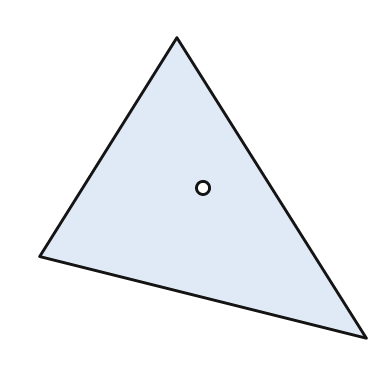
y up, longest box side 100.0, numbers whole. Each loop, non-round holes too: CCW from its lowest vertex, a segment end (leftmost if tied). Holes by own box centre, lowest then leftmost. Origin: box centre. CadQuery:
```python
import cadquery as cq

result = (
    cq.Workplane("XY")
    .moveTo(50.0, -46.0)
    .lineTo(-8.0, 46.0)
    .lineTo(-50.0, -21.0)
    .close()
    .moveTo(0.0, 0.0)
    .circle(2.0)
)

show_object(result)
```